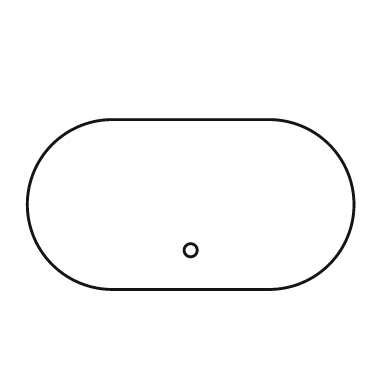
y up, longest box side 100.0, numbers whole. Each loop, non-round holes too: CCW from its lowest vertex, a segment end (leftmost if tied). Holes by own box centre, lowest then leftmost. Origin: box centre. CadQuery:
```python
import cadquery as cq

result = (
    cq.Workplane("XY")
    .moveTo(-24.0, -26.0)
    .lineTo(24.0, -26.0)
    .threePointArc((50.0, 0.0), (24.0, 26.0))
    .lineTo(-24.0, 26.0)
    .threePointArc((-50.0, 0.0), (-24.0, -26.0))
    .close()
    .moveTo(0.0, -14.0)
    .circle(2.0)
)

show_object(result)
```